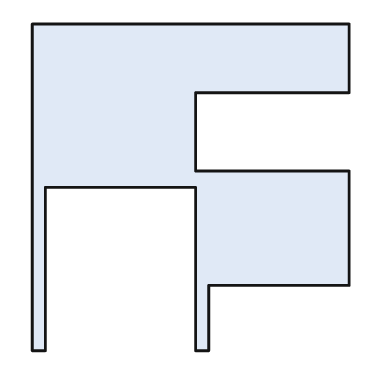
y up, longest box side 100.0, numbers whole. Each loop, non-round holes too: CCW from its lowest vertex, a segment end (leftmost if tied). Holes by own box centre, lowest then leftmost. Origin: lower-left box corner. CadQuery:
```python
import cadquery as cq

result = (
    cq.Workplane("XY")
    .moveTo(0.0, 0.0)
    .lineTo(4.0, 0.0)
    .lineTo(4.0, 50.0)
    .lineTo(50.0, 50.0)
    .lineTo(50.0, 0.0)
    .lineTo(54.0, 0.0)
    .lineTo(54.0, 20.0)
    .lineTo(97.0, 20.0)
    .lineTo(97.0, 55.0)
    .lineTo(50.0, 55.0)
    .lineTo(50.0, 79.0)
    .lineTo(97.0, 79.0)
    .lineTo(97.0, 100.0)
    .lineTo(0.0, 100.0)
    .close()
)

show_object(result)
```